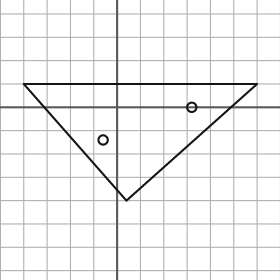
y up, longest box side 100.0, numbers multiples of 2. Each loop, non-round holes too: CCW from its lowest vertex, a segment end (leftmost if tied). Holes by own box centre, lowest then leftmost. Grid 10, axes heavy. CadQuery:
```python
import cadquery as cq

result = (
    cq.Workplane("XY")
    .moveTo(4.0, -40.0)
    .lineTo(60.0, 10.0)
    .lineTo(-40.0, 10.0)
    .close()
    .moveTo(-6.0, -14.0)
    .circle(2.0)
    .moveTo(32.0, 0.0)
    .circle(2.0)
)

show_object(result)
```